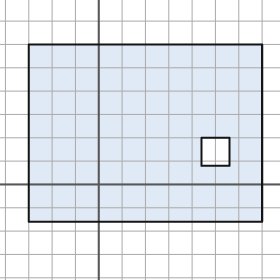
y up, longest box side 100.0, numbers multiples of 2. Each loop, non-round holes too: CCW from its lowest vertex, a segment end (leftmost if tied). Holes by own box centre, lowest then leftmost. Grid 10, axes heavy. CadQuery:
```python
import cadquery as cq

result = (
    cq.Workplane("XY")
    .moveTo(-30.0, -16.0)
    .lineTo(70.0, -16.0)
    .lineTo(70.0, 60.0)
    .lineTo(-30.0, 60.0)
    .close()
    .moveTo(44.0, 8.0)
    .lineTo(56.0, 8.0)
    .lineTo(56.0, 20.0)
    .lineTo(44.0, 20.0)
    .close()
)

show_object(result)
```